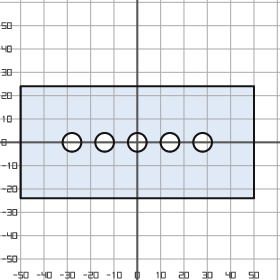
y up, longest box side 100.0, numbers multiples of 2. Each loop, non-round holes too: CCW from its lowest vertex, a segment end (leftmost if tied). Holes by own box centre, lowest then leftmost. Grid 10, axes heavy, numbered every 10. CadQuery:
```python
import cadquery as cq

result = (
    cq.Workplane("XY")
    .moveTo(-50.0, -24.0)
    .lineTo(50.0, -24.0)
    .lineTo(50.0, 24.0)
    .lineTo(-50.0, 24.0)
    .close()
    .moveTo(-28.0, 0.0)
    .circle(4.0)
    .moveTo(-14.0, 0.0)
    .circle(4.0)
    .moveTo(0.0, 0.0)
    .circle(4.0)
    .moveTo(14.0, 0.0)
    .circle(4.0)
    .moveTo(28.0, 0.0)
    .circle(4.0)
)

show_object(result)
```